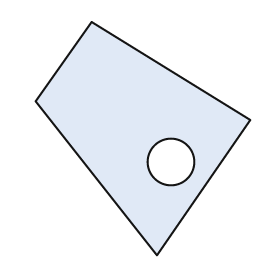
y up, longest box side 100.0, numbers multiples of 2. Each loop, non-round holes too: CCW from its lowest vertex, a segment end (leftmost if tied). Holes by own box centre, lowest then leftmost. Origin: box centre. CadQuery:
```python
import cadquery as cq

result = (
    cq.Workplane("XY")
    .moveTo(6.0, -50.0)
    .lineTo(46.0, 8.0)
    .lineTo(-22.0, 50.0)
    .lineTo(-46.0, 16.0)
    .close()
    .moveTo(12.0, -10.0)
    .circle(10.0)
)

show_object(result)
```